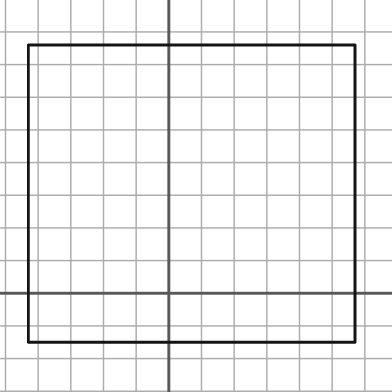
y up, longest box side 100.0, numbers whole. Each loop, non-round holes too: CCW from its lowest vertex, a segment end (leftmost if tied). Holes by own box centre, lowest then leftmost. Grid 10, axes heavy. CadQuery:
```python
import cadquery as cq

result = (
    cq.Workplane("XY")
    .moveTo(-43.0, -15.0)
    .lineTo(57.0, -15.0)
    .lineTo(57.0, 76.0)
    .lineTo(-43.0, 76.0)
    .close()
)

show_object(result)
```